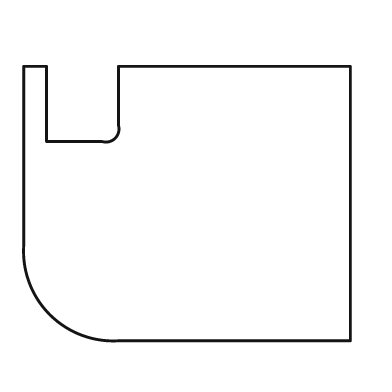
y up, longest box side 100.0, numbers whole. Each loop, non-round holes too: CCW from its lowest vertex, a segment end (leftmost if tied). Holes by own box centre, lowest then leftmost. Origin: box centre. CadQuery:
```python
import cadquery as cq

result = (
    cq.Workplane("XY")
    .moveTo(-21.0, -42.0)
    .lineTo(50.0, -42.0)
    .lineTo(50.0, 42.0)
    .lineTo(-21.0, 42.0)
    .lineTo(-21.0, 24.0)
    .threePointArc((-22.0, 20.0), (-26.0, 19.0))
    .lineTo(-43.0, 19.0)
    .lineTo(-43.0, 42.0)
    .lineTo(-50.0, 42.0)
    .lineTo(-50.0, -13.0)
    .threePointArc((-42.0, -34.0), (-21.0, -42.0))
    .close()
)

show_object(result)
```